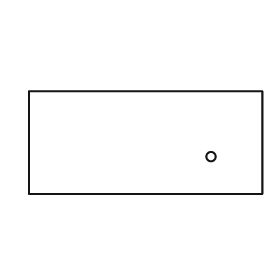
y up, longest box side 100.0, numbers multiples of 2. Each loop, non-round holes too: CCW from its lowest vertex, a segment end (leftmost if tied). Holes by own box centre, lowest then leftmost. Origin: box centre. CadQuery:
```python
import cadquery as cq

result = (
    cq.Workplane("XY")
    .moveTo(-50.0, -22.0)
    .lineTo(50.0, -22.0)
    .lineTo(50.0, 22.0)
    .lineTo(-50.0, 22.0)
    .close()
    .moveTo(28.0, -6.0)
    .circle(2.0)
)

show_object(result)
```